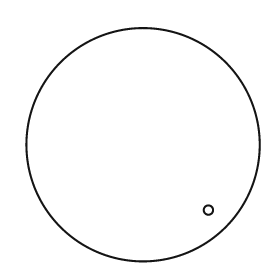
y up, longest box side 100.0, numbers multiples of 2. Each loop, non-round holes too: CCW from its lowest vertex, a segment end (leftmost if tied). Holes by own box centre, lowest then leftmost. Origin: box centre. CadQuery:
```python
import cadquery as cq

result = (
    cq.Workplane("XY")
    .moveTo(0.0, 0.0)
    .circle(50.0)
    .moveTo(28.0, -28.0)
    .circle(2.0)
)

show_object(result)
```